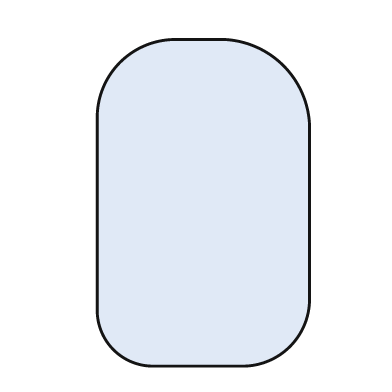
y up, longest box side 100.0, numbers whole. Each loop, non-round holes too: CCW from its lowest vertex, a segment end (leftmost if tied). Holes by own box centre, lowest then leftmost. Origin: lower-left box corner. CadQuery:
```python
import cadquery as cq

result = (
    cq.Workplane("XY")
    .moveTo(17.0, 0.0)
    .lineTo(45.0, 0.0)
    .threePointArc((59.0, 6.0), (65.0, 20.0))
    .lineTo(65.0, 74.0)
    .threePointArc((57.0, 92.0), (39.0, 100.0))
    .lineTo(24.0, 100.0)
    .threePointArc((7.0, 93.0), (0.0, 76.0))
    .lineTo(0.0, 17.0)
    .threePointArc((5.0, 5.0), (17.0, 0.0))
    .close()
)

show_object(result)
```